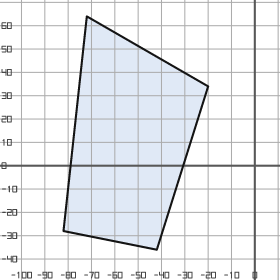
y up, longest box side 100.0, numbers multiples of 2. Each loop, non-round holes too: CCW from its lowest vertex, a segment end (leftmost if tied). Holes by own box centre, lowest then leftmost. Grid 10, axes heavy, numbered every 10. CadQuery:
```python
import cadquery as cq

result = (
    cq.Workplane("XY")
    .moveTo(-42.0, -36.0)
    .lineTo(-20.0, 34.0)
    .lineTo(-72.0, 64.0)
    .lineTo(-82.0, -28.0)
    .close()
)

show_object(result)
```